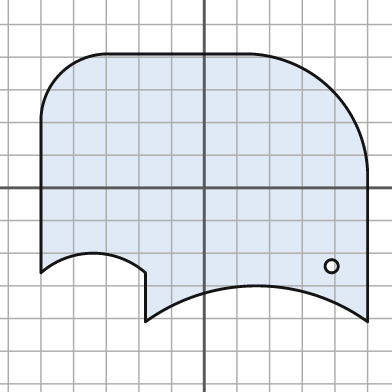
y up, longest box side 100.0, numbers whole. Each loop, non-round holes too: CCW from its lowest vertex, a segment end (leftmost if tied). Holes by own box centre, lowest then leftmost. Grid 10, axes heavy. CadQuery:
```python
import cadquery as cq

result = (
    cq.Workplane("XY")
    .moveTo(-18.0, -41.0)
    .threePointArc((16.0, -30.0), (50.0, -41.0))
    .lineTo(50.0, 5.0)
    .threePointArc((39.0, 30.0), (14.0, 41.0))
    .lineTo(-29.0, 41.0)
    .threePointArc((-44.0, 35.0), (-50.0, 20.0))
    .lineTo(-50.0, -26.0)
    .threePointArc((-34.0, -20.0), (-18.0, -26.0))
    .close()
    .moveTo(39.0, -24.0)
    .circle(2.0)
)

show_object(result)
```